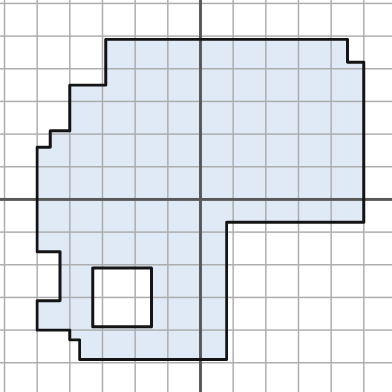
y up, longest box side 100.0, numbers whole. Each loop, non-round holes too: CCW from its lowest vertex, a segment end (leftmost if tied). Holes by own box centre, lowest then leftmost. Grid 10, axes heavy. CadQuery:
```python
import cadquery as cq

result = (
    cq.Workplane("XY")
    .moveTo(-37.0, -49.0)
    .lineTo(8.0, -49.0)
    .lineTo(8.0, -7.0)
    .lineTo(50.0, -7.0)
    .lineTo(50.0, 42.0)
    .lineTo(45.0, 42.0)
    .lineTo(45.0, 49.0)
    .lineTo(-29.0, 49.0)
    .lineTo(-29.0, 35.0)
    .lineTo(-40.0, 35.0)
    .lineTo(-40.0, 21.0)
    .lineTo(-46.0, 21.0)
    .lineTo(-46.0, 16.0)
    .lineTo(-50.0, 16.0)
    .lineTo(-50.0, -16.0)
    .lineTo(-43.0, -16.0)
    .lineTo(-43.0, -31.0)
    .lineTo(-50.0, -31.0)
    .lineTo(-50.0, -40.0)
    .lineTo(-40.0, -40.0)
    .lineTo(-40.0, -43.0)
    .lineTo(-37.0, -43.0)
    .close()
    .moveTo(-33.0, -39.0)
    .lineTo(-15.0, -39.0)
    .lineTo(-15.0, -21.0)
    .lineTo(-33.0, -21.0)
    .close()
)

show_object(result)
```